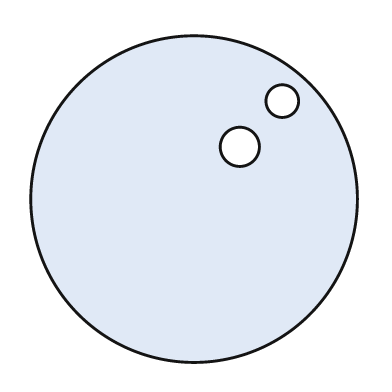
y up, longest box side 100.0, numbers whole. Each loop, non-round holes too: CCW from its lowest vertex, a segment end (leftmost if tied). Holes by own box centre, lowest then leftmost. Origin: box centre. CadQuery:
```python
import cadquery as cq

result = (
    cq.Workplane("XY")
    .moveTo(0.0, 0.0)
    .circle(50.0)
    .moveTo(14.0, 16.0)
    .circle(6.0)
    .moveTo(27.0, 30.0)
    .circle(5.0)
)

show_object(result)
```